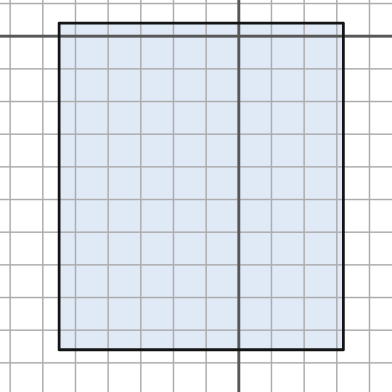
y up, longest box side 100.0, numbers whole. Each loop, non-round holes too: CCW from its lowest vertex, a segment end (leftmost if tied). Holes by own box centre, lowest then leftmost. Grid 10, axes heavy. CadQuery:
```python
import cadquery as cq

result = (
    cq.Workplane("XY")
    .moveTo(-55.0, -96.0)
    .lineTo(32.0, -96.0)
    .lineTo(32.0, 4.0)
    .lineTo(-55.0, 4.0)
    .close()
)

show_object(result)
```